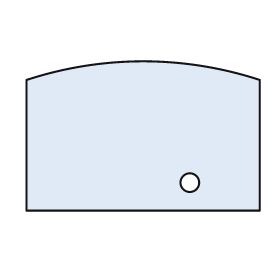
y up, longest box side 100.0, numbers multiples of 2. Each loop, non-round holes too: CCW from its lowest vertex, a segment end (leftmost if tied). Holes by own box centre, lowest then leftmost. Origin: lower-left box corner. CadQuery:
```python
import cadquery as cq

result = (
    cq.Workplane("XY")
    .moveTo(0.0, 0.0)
    .lineTo(100.0, 0.0)
    .lineTo(100.0, 56.0)
    .threePointArc((50.0, 64.0), (0.0, 56.0))
    .close()
    .moveTo(70.0, 12.0)
    .circle(4.0)
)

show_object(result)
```